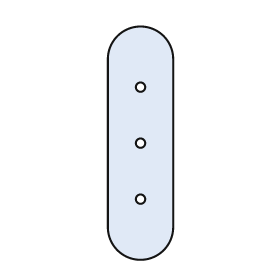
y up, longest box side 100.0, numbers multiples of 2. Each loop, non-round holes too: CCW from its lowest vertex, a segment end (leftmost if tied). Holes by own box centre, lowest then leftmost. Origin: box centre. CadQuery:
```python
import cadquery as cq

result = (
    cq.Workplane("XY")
    .moveTo(-14.0, -36.0)
    .threePointArc((0.0, -50.0), (14.0, -36.0))
    .lineTo(14.0, 36.0)
    .threePointArc((0.0, 50.0), (-14.0, 36.0))
    .close()
    .moveTo(0.0, -24.0)
    .circle(2.0)
    .moveTo(0.0, 0.0)
    .circle(2.0)
    .moveTo(0.0, 24.0)
    .circle(2.0)
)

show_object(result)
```